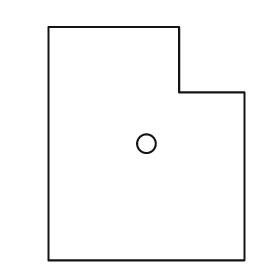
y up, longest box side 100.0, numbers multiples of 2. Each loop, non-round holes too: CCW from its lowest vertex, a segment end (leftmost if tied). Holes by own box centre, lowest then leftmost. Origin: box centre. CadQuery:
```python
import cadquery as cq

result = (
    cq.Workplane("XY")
    .moveTo(-42.0, -50.0)
    .lineTo(42.0, -50.0)
    .lineTo(42.0, 22.0)
    .lineTo(14.0, 22.0)
    .lineTo(14.0, 50.0)
    .lineTo(-42.0, 50.0)
    .close()
    .moveTo(0.0, 0.0)
    .circle(4.0)
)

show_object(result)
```